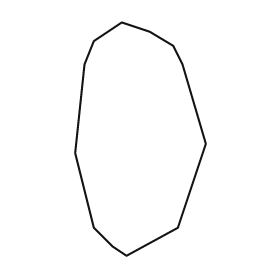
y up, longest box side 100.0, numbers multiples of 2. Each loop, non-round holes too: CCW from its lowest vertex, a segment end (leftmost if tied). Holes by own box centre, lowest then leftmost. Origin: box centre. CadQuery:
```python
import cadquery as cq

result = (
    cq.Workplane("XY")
    .moveTo(-6.0, -50.0)
    .lineTo(16.0, -38.0)
    .lineTo(28.0, -2.0)
    .lineTo(18.0, 32.0)
    .lineTo(14.0, 40.0)
    .lineTo(4.0, 46.0)
    .lineTo(-8.0, 50.0)
    .lineTo(-20.0, 42.0)
    .lineTo(-24.0, 32.0)
    .lineTo(-28.0, -6.0)
    .lineTo(-20.0, -38.0)
    .lineTo(-12.0, -46.0)
    .close()
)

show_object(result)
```